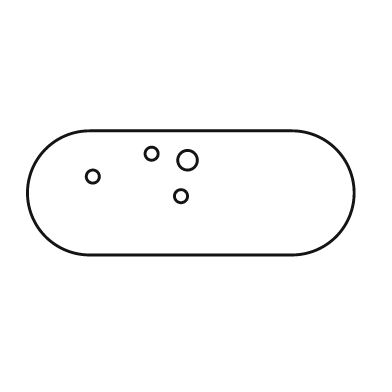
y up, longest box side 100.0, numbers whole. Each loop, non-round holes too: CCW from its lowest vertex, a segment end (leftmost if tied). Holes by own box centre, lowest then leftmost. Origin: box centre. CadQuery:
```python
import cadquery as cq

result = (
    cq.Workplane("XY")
    .moveTo(-31.0, -19.0)
    .lineTo(31.0, -19.0)
    .threePointArc((50.0, 0.0), (31.0, 19.0))
    .lineTo(-31.0, 19.0)
    .threePointArc((-50.0, 0.0), (-31.0, -19.0))
    .close()
    .moveTo(-3.0, -1.0)
    .circle(2.0)
    .moveTo(-30.0, 5.0)
    .circle(2.0)
    .moveTo(-1.0, 10.0)
    .circle(3.0)
    .moveTo(-12.0, 12.0)
    .circle(2.0)
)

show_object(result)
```